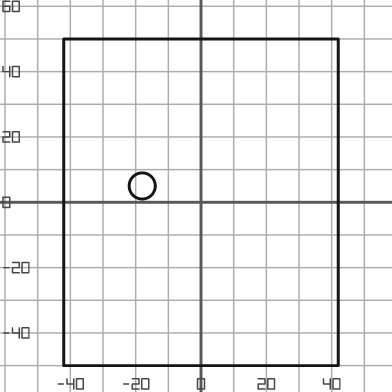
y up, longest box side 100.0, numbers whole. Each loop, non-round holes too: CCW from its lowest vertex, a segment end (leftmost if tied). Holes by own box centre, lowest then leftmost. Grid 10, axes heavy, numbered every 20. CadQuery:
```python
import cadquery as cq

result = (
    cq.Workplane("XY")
    .moveTo(-42.0, -50.0)
    .lineTo(42.0, -50.0)
    .lineTo(42.0, 50.0)
    .lineTo(-42.0, 50.0)
    .close()
    .moveTo(-18.0, 5.0)
    .circle(4.0)
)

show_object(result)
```